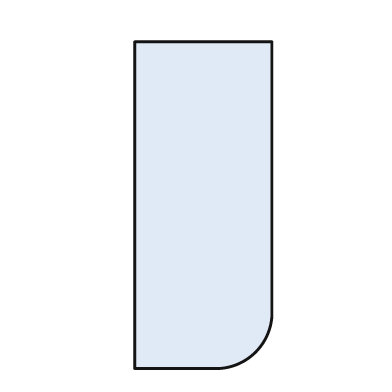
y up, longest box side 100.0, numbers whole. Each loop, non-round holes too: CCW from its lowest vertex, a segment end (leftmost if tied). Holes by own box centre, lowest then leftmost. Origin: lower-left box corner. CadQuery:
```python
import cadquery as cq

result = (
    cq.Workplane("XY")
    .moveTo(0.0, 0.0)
    .lineTo(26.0, 0.0)
    .threePointArc((37.0, 5.0), (42.0, 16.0))
    .lineTo(42.0, 100.0)
    .lineTo(0.0, 100.0)
    .close()
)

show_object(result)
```